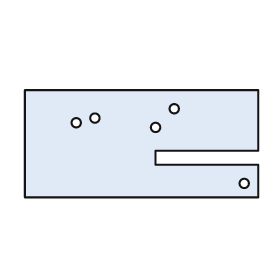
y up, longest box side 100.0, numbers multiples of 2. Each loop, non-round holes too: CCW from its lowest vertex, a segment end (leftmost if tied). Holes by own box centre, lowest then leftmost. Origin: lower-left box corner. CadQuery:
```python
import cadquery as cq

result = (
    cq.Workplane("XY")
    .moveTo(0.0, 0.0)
    .lineTo(100.0, 0.0)
    .lineTo(100.0, 14.0)
    .lineTo(56.0, 14.0)
    .lineTo(56.0, 20.0)
    .lineTo(100.0, 20.0)
    .lineTo(100.0, 46.0)
    .lineTo(0.0, 46.0)
    .close()
    .moveTo(94.0, 6.0)
    .circle(2.0)
    .moveTo(56.0, 30.0)
    .circle(2.0)
    .moveTo(22.0, 32.0)
    .circle(2.0)
    .moveTo(30.0, 34.0)
    .circle(2.0)
    .moveTo(64.0, 38.0)
    .circle(2.0)
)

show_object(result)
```